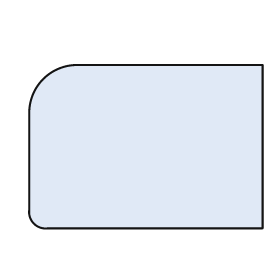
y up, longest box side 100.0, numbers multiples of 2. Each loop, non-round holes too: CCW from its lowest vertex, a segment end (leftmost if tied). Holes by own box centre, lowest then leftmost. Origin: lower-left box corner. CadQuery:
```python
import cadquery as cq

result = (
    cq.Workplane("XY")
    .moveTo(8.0, 0.0)
    .lineTo(100.0, 0.0)
    .lineTo(100.0, 70.0)
    .lineTo(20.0, 70.0)
    .threePointArc((6.0, 64.0), (0.0, 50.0))
    .lineTo(0.0, 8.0)
    .threePointArc((2.0, 2.0), (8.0, 0.0))
    .close()
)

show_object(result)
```